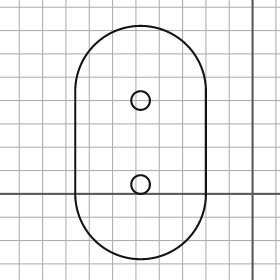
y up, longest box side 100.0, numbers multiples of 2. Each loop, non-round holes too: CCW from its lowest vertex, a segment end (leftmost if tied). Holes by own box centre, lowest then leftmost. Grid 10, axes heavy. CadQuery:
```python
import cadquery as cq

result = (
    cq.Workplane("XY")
    .moveTo(-76.0, 0.0)
    .threePointArc((-48.0, -28.0), (-20.0, 0.0))
    .lineTo(-20.0, 44.0)
    .threePointArc((-48.0, 72.0), (-76.0, 44.0))
    .close()
    .moveTo(-48.0, 4.0)
    .circle(4.0)
    .moveTo(-48.0, 40.0)
    .circle(4.0)
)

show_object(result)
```